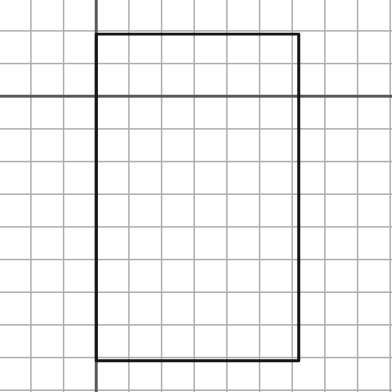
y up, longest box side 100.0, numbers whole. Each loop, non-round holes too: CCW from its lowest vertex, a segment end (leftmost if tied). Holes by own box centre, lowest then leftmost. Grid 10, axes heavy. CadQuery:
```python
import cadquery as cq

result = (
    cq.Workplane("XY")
    .moveTo(0.0, -81.0)
    .lineTo(62.0, -81.0)
    .lineTo(62.0, 19.0)
    .lineTo(0.0, 19.0)
    .close()
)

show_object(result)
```